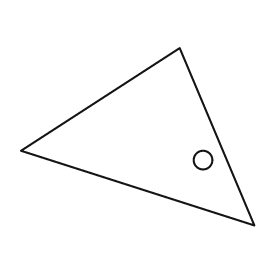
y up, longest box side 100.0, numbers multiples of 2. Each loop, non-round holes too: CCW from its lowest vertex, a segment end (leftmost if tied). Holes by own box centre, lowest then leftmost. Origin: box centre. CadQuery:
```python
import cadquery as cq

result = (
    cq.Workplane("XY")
    .moveTo(50.0, -38.0)
    .lineTo(18.0, 38.0)
    .lineTo(-50.0, -6.0)
    .close()
    .moveTo(28.0, -10.0)
    .circle(4.0)
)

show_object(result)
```